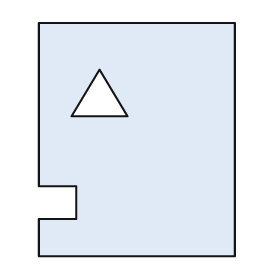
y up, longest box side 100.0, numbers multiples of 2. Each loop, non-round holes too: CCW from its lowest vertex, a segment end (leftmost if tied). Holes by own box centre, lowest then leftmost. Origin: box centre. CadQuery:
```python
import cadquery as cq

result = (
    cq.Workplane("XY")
    .moveTo(-42.0, -50.0)
    .lineTo(42.0, -50.0)
    .lineTo(42.0, 50.0)
    .lineTo(-42.0, 50.0)
    .lineTo(-42.0, -20.0)
    .lineTo(-26.0, -20.0)
    .lineTo(-26.0, -34.0)
    .lineTo(-42.0, -34.0)
    .close()
    .moveTo(-28.0, 10.0)
    .lineTo(-4.0, 10.0)
    .lineTo(-16.0, 30.0)
    .close()
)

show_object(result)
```